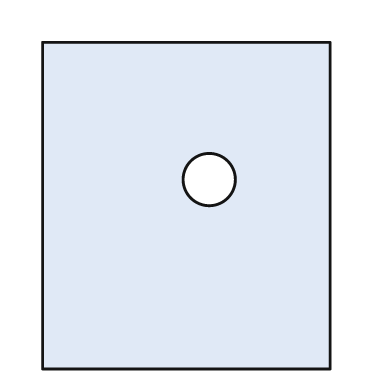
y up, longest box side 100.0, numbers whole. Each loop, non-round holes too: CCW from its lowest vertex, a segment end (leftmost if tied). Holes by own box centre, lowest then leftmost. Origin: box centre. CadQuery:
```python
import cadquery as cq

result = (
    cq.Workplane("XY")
    .moveTo(-44.0, -50.0)
    .lineTo(44.0, -50.0)
    .lineTo(44.0, 50.0)
    .lineTo(-44.0, 50.0)
    .close()
    .moveTo(7.0, 8.0)
    .circle(8.0)
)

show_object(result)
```